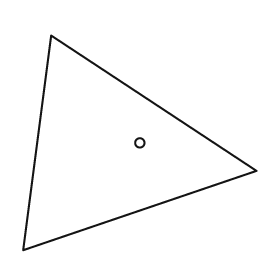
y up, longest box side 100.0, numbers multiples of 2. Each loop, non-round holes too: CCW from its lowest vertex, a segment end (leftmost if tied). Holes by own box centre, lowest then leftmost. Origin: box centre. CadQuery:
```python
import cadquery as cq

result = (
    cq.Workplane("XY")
    .moveTo(-50.0, -46.0)
    .lineTo(50.0, -12.0)
    .lineTo(-38.0, 46.0)
    .close()
    .moveTo(0.0, 0.0)
    .circle(2.0)
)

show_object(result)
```